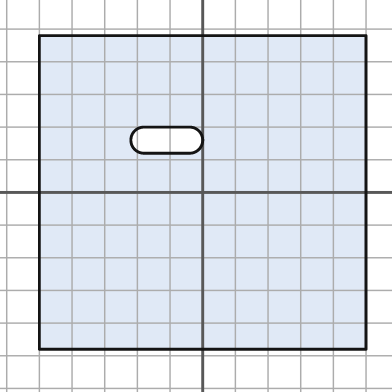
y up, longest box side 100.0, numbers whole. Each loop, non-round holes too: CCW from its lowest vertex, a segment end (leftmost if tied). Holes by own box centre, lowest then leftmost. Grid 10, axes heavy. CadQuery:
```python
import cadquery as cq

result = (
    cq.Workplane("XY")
    .moveTo(-50.0, -48.0)
    .lineTo(50.0, -48.0)
    .lineTo(50.0, 48.0)
    .lineTo(-50.0, 48.0)
    .close()
    .moveTo(-18.0, 12.0)
    .lineTo(-4.0, 12.0)
    .threePointArc((0.0, 16.0), (-4.0, 20.0))
    .lineTo(-18.0, 20.0)
    .threePointArc((-22.0, 16.0), (-18.0, 12.0))
    .close()
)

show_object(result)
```